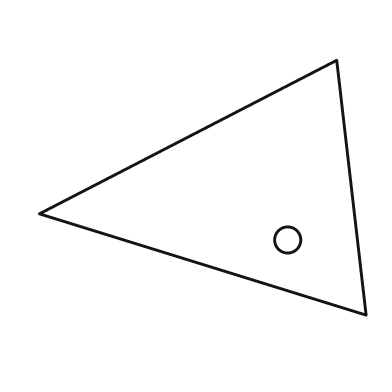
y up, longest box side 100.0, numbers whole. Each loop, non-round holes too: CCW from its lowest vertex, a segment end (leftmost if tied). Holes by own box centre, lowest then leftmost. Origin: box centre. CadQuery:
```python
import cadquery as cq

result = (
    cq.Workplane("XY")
    .moveTo(50.0, -39.0)
    .lineTo(41.0, 39.0)
    .lineTo(-50.0, -8.0)
    .close()
    .moveTo(26.0, -16.0)
    .circle(4.0)
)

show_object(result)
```